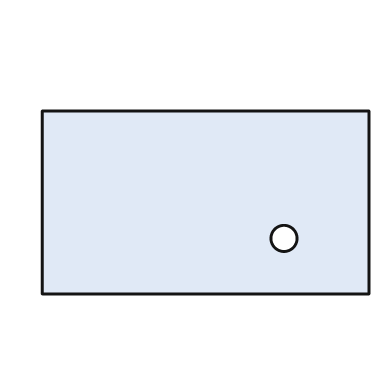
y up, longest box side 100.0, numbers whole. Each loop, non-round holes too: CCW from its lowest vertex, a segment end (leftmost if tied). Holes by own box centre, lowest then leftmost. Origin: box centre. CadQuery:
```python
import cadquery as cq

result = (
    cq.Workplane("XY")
    .moveTo(-50.0, -28.0)
    .lineTo(50.0, -28.0)
    .lineTo(50.0, 28.0)
    .lineTo(-50.0, 28.0)
    .close()
    .moveTo(24.0, -11.0)
    .circle(4.0)
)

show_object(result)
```